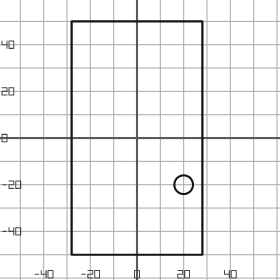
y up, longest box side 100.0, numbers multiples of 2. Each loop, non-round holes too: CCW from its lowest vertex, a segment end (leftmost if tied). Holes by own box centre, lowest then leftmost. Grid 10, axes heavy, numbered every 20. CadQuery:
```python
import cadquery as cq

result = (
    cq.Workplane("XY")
    .moveTo(-28.0, -50.0)
    .lineTo(28.0, -50.0)
    .lineTo(28.0, 50.0)
    .lineTo(-28.0, 50.0)
    .close()
    .moveTo(20.0, -20.0)
    .circle(4.0)
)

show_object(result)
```